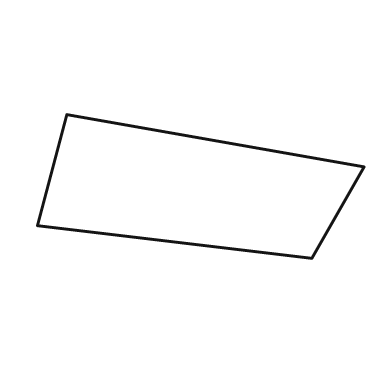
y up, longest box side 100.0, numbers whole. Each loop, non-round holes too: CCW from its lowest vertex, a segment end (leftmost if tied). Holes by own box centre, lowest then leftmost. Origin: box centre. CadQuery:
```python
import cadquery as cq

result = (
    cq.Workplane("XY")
    .moveTo(34.0, -22.0)
    .lineTo(50.0, 6.0)
    .lineTo(-41.0, 22.0)
    .lineTo(-50.0, -12.0)
    .close()
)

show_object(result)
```